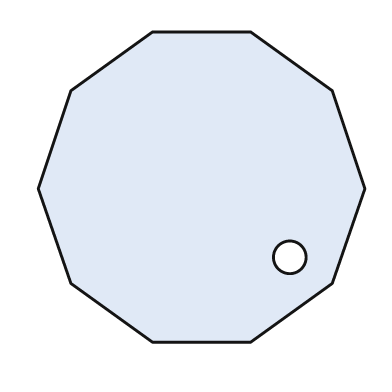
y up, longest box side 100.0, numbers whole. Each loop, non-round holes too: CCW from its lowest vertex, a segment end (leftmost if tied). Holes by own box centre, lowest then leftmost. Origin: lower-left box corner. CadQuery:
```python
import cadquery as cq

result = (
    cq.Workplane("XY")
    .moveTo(35.0, 0.0)
    .lineTo(65.0, 0.0)
    .lineTo(90.0, 18.0)
    .lineTo(100.0, 47.0)
    .lineTo(90.0, 77.0)
    .lineTo(65.0, 95.0)
    .lineTo(35.0, 95.0)
    .lineTo(10.0, 77.0)
    .lineTo(0.0, 47.0)
    .lineTo(10.0, 18.0)
    .close()
    .moveTo(77.0, 26.0)
    .circle(5.0)
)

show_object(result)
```